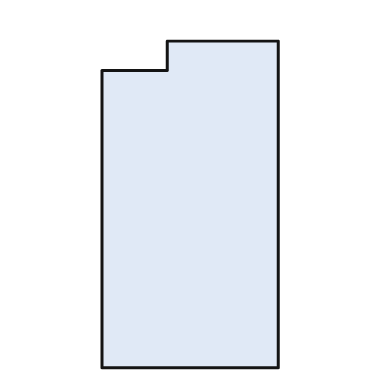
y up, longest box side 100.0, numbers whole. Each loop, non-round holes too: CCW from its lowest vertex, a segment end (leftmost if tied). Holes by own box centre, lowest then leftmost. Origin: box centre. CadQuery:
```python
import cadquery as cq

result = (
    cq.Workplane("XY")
    .moveTo(-27.0, -50.0)
    .lineTo(27.0, -50.0)
    .lineTo(27.0, 50.0)
    .lineTo(-7.0, 50.0)
    .lineTo(-7.0, 41.0)
    .lineTo(-27.0, 41.0)
    .close()
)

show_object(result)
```